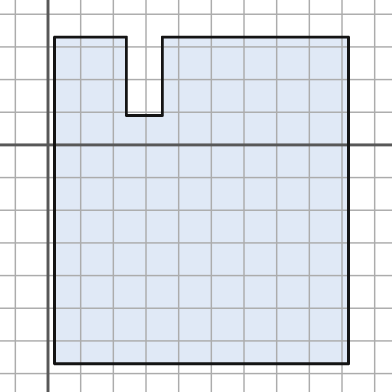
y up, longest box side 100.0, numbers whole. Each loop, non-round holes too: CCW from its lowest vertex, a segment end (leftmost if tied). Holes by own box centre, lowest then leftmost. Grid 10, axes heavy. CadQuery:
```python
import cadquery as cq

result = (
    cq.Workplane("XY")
    .moveTo(2.0, -67.0)
    .lineTo(92.0, -67.0)
    .lineTo(92.0, 33.0)
    .lineTo(35.0, 33.0)
    .lineTo(35.0, 9.0)
    .lineTo(24.0, 9.0)
    .lineTo(24.0, 33.0)
    .lineTo(2.0, 33.0)
    .close()
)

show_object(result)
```